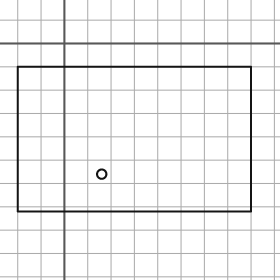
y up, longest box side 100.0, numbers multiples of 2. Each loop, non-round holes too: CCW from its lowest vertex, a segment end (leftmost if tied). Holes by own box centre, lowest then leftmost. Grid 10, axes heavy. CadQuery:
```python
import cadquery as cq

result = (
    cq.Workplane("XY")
    .moveTo(-20.0, -72.0)
    .lineTo(80.0, -72.0)
    .lineTo(80.0, -10.0)
    .lineTo(-20.0, -10.0)
    .close()
    .moveTo(16.0, -56.0)
    .circle(2.0)
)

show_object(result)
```